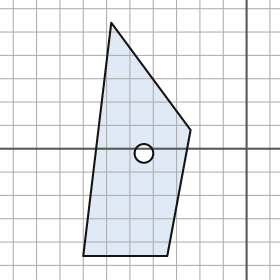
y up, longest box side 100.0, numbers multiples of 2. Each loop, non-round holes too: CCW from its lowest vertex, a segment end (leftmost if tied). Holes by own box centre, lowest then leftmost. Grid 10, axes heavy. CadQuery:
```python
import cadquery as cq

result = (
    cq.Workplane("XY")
    .moveTo(-70.0, -46.0)
    .lineTo(-34.0, -46.0)
    .lineTo(-24.0, 8.0)
    .lineTo(-58.0, 54.0)
    .close()
    .moveTo(-44.0, -2.0)
    .circle(4.0)
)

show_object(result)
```